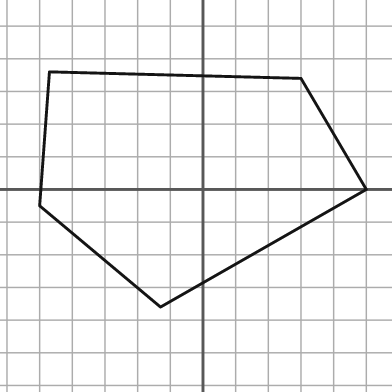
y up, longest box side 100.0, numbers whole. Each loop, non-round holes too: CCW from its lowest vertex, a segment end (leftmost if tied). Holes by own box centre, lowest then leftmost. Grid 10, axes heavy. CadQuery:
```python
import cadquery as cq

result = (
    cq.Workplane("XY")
    .moveTo(-13.0, -36.0)
    .lineTo(50.0, 0.0)
    .lineTo(30.0, 34.0)
    .lineTo(-47.0, 36.0)
    .lineTo(-50.0, -5.0)
    .close()
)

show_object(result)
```